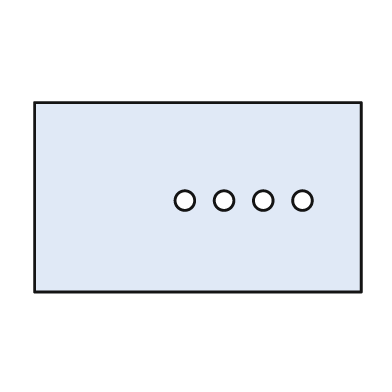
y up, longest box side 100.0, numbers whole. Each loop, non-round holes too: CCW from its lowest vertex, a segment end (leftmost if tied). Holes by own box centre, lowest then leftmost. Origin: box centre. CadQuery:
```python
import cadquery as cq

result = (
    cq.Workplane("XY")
    .moveTo(-50.0, -29.0)
    .lineTo(50.0, -29.0)
    .lineTo(50.0, 29.0)
    .lineTo(-50.0, 29.0)
    .close()
    .moveTo(-4.0, -1.0)
    .circle(3.0)
    .moveTo(8.0, -1.0)
    .circle(3.0)
    .moveTo(20.0, -1.0)
    .circle(3.0)
    .moveTo(32.0, -1.0)
    .circle(3.0)
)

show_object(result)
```